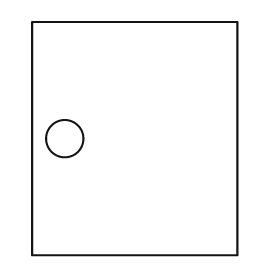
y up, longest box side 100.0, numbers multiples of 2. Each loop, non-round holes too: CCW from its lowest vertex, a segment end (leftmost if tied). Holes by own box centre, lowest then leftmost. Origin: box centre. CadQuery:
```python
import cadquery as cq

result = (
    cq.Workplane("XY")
    .moveTo(-44.0, -50.0)
    .lineTo(44.0, -50.0)
    .lineTo(44.0, 50.0)
    .lineTo(-44.0, 50.0)
    .close()
    .moveTo(-30.0, 0.0)
    .circle(8.0)
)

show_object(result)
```